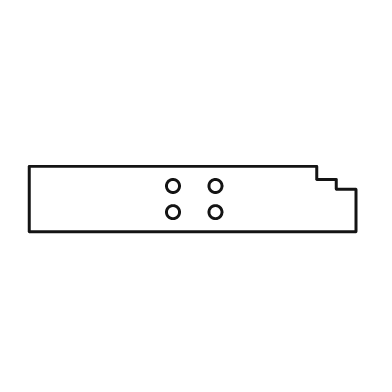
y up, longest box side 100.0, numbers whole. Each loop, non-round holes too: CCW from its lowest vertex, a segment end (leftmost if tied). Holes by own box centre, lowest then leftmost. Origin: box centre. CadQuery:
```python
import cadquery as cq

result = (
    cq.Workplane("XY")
    .moveTo(-50.0, -10.0)
    .lineTo(50.0, -10.0)
    .lineTo(50.0, 3.0)
    .lineTo(44.0, 3.0)
    .lineTo(44.0, 6.0)
    .lineTo(38.0, 6.0)
    .lineTo(38.0, 10.0)
    .lineTo(-50.0, 10.0)
    .close()
    .moveTo(-6.0, -4.0)
    .circle(2.0)
    .moveTo(7.0, -4.0)
    .circle(2.0)
    .moveTo(-6.0, 4.0)
    .circle(2.0)
    .moveTo(7.0, 4.0)
    .circle(2.0)
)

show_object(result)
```